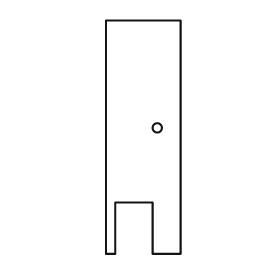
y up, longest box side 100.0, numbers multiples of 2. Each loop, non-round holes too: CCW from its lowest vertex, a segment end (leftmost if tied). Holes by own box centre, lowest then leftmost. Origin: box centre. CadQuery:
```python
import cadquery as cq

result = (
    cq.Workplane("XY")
    .moveTo(-16.0, -50.0)
    .lineTo(-12.0, -50.0)
    .lineTo(-12.0, -28.0)
    .lineTo(4.0, -28.0)
    .lineTo(4.0, -50.0)
    .lineTo(16.0, -50.0)
    .lineTo(16.0, 50.0)
    .lineTo(-16.0, 50.0)
    .close()
    .moveTo(6.0, 4.0)
    .circle(2.0)
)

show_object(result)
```